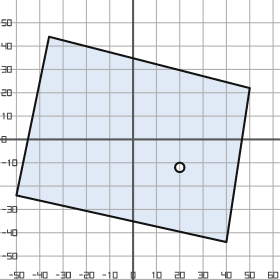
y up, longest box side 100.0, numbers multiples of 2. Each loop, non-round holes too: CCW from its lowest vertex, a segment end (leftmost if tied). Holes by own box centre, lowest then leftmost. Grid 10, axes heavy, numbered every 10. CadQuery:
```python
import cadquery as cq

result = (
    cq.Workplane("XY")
    .moveTo(40.0, -44.0)
    .lineTo(50.0, 22.0)
    .lineTo(-36.0, 44.0)
    .lineTo(-50.0, -24.0)
    .close()
    .moveTo(20.0, -12.0)
    .circle(2.0)
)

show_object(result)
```